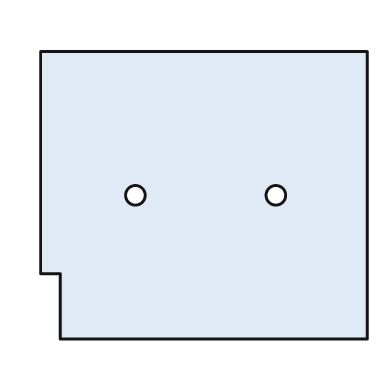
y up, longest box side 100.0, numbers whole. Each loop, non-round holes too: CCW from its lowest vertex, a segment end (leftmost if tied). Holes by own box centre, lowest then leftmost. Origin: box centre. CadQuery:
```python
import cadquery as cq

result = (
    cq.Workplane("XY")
    .moveTo(-44.0, -44.0)
    .lineTo(50.0, -44.0)
    .lineTo(50.0, 44.0)
    .lineTo(-50.0, 44.0)
    .lineTo(-50.0, -24.0)
    .lineTo(-44.0, -24.0)
    .close()
    .moveTo(-21.0, 0.0)
    .circle(3.0)
    .moveTo(22.0, 0.0)
    .circle(3.0)
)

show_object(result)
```